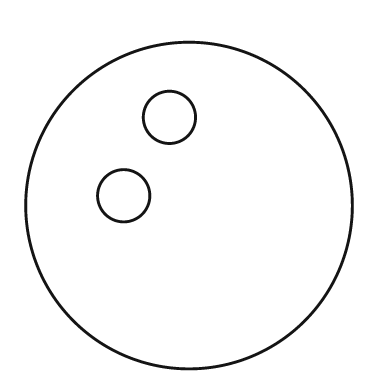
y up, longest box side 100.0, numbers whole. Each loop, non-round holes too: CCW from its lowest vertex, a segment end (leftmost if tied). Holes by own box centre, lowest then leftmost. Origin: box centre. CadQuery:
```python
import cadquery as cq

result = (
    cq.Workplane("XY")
    .moveTo(0.0, 0.0)
    .circle(50.0)
    .moveTo(-20.0, 3.0)
    .circle(8.0)
    .moveTo(-6.0, 27.0)
    .circle(8.0)
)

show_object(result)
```